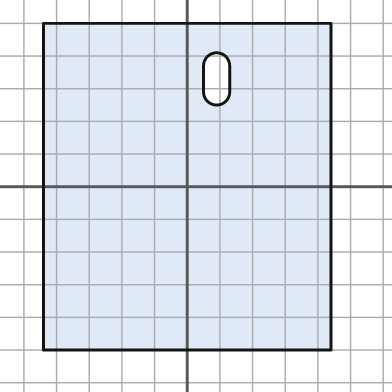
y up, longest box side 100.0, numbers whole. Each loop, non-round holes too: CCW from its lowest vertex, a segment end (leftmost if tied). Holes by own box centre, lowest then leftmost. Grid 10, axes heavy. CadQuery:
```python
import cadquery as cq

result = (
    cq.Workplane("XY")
    .moveTo(-44.0, -50.0)
    .lineTo(44.0, -50.0)
    .lineTo(44.0, 50.0)
    .lineTo(-44.0, 50.0)
    .close()
    .moveTo(5.0, 29.0)
    .threePointArc((9.0, 25.0), (13.0, 29.0))
    .lineTo(13.0, 37.0)
    .threePointArc((9.0, 41.0), (5.0, 37.0))
    .close()
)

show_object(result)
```